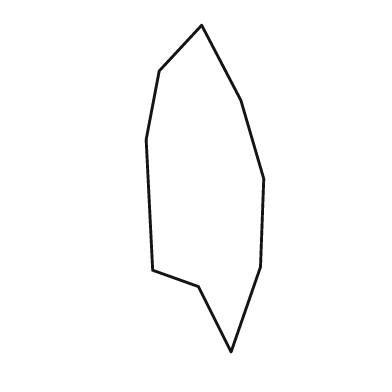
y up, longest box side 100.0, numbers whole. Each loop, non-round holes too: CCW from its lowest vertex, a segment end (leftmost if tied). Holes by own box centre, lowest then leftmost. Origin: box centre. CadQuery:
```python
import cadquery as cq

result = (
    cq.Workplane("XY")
    .moveTo(8.0, -50.0)
    .lineTo(17.0, -24.0)
    .lineTo(18.0, 3.0)
    .lineTo(11.0, 27.0)
    .lineTo(-1.0, 50.0)
    .lineTo(-14.0, 36.0)
    .lineTo(-18.0, 15.0)
    .lineTo(-16.0, -25.0)
    .lineTo(-2.0, -30.0)
    .close()
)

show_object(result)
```